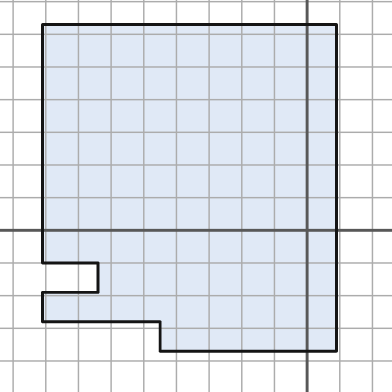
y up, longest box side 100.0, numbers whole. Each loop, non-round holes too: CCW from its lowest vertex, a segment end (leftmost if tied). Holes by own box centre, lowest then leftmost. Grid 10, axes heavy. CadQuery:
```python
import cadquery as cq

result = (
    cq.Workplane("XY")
    .moveTo(-45.0, -37.0)
    .lineTo(9.0, -37.0)
    .lineTo(9.0, 63.0)
    .lineTo(-81.0, 63.0)
    .lineTo(-81.0, -10.0)
    .lineTo(-64.0, -10.0)
    .lineTo(-64.0, -19.0)
    .lineTo(-81.0, -19.0)
    .lineTo(-81.0, -28.0)
    .lineTo(-45.0, -28.0)
    .close()
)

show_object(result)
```